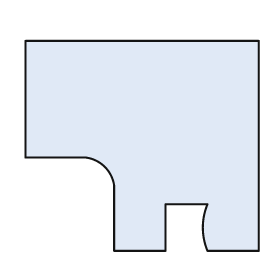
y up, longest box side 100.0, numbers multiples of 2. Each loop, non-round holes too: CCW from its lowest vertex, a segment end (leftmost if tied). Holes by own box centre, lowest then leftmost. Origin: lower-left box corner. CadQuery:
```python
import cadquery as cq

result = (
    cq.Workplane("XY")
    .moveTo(38.0, 0.0)
    .lineTo(60.0, 0.0)
    .lineTo(60.0, 20.0)
    .lineTo(78.0, 20.0)
    .threePointArc((76.0, 10.0), (78.0, 0.0))
    .lineTo(100.0, 0.0)
    .lineTo(100.0, 90.0)
    .lineTo(0.0, 90.0)
    .lineTo(0.0, 40.0)
    .lineTo(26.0, 40.0)
    .threePointArc((34.0, 36.0), (38.0, 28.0))
    .close()
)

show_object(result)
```